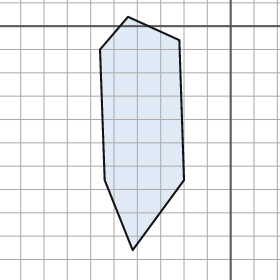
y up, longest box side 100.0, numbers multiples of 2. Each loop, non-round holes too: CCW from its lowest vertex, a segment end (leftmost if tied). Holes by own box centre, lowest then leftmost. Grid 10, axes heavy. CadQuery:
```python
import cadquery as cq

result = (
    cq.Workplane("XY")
    .moveTo(-42.0, -96.0)
    .lineTo(-20.0, -66.0)
    .lineTo(-22.0, -6.0)
    .lineTo(-44.0, 4.0)
    .lineTo(-56.0, -10.0)
    .lineTo(-54.0, -66.0)
    .close()
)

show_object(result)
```